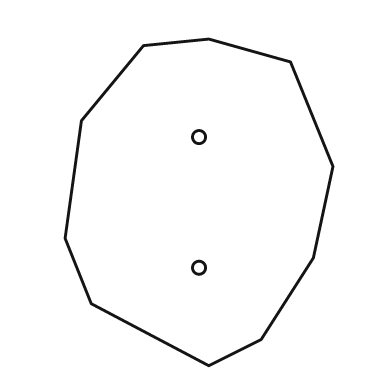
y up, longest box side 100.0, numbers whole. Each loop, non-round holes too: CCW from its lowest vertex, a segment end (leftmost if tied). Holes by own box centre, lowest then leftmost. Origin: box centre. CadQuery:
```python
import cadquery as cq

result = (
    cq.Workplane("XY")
    .moveTo(3.0, -50.0)
    .lineTo(19.0, -42.0)
    .lineTo(35.0, -17.0)
    .lineTo(41.0, 11.0)
    .lineTo(28.0, 43.0)
    .lineTo(3.0, 50.0)
    .lineTo(-17.0, 48.0)
    .lineTo(-36.0, 25.0)
    .lineTo(-41.0, -11.0)
    .lineTo(-33.0, -31.0)
    .close()
    .moveTo(0.0, -20.0)
    .circle(2.0)
    .moveTo(0.0, 20.0)
    .circle(2.0)
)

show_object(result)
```